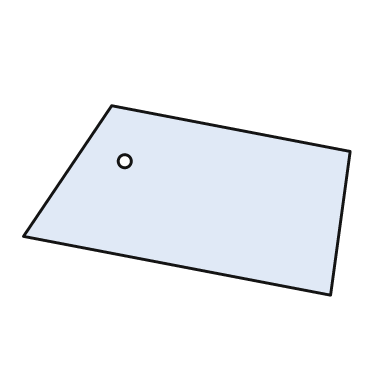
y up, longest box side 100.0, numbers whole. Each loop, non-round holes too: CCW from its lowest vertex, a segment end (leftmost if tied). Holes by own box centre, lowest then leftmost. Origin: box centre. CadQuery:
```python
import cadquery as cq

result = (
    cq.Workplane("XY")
    .moveTo(44.0, -29.0)
    .lineTo(50.0, 15.0)
    .lineTo(-23.0, 29.0)
    .lineTo(-50.0, -11.0)
    .close()
    .moveTo(-19.0, 12.0)
    .circle(2.0)
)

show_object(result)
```